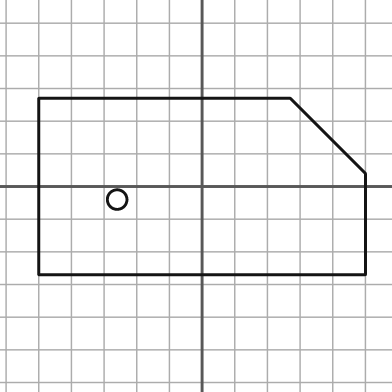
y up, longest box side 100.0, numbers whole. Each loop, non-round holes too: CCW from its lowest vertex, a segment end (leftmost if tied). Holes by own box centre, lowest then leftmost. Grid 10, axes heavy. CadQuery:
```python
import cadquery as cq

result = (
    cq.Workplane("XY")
    .moveTo(-50.0, -27.0)
    .lineTo(50.0, -27.0)
    .lineTo(50.0, 4.0)
    .lineTo(27.0, 27.0)
    .lineTo(-50.0, 27.0)
    .close()
    .moveTo(-26.0, -4.0)
    .circle(3.0)
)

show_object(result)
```